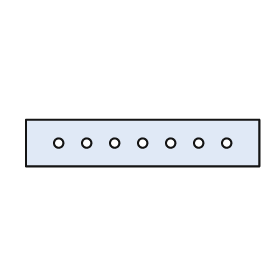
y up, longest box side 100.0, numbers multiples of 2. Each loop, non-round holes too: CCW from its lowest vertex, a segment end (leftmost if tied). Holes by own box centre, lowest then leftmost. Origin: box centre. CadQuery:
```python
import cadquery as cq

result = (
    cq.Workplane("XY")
    .moveTo(-50.0, -10.0)
    .lineTo(50.0, -10.0)
    .lineTo(50.0, 10.0)
    .lineTo(-50.0, 10.0)
    .close()
    .moveTo(-36.0, 0.0)
    .circle(2.0)
    .moveTo(-24.0, 0.0)
    .circle(2.0)
    .moveTo(-12.0, 0.0)
    .circle(2.0)
    .moveTo(0.0, 0.0)
    .circle(2.0)
    .moveTo(12.0, 0.0)
    .circle(2.0)
    .moveTo(24.0, 0.0)
    .circle(2.0)
    .moveTo(36.0, 0.0)
    .circle(2.0)
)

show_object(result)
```